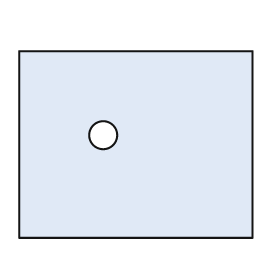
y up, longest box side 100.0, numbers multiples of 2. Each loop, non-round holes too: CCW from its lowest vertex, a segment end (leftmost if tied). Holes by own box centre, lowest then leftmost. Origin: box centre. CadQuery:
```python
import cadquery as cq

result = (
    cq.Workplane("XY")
    .moveTo(-50.0, -40.0)
    .lineTo(50.0, -40.0)
    .lineTo(50.0, 40.0)
    .lineTo(-50.0, 40.0)
    .close()
    .moveTo(-14.0, 4.0)
    .circle(6.0)
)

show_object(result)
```